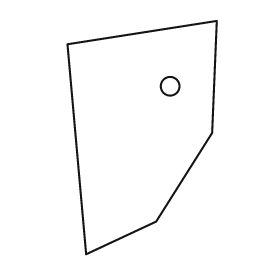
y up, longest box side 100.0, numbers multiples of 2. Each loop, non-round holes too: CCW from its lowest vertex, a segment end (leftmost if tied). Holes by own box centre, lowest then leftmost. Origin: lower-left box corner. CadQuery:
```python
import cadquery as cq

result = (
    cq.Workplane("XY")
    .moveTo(8.0, 0.0)
    .lineTo(38.0, 14.0)
    .lineTo(62.0, 52.0)
    .lineTo(64.0, 100.0)
    .lineTo(0.0, 90.0)
    .close()
    .moveTo(44.0, 72.0)
    .circle(4.0)
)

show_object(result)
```